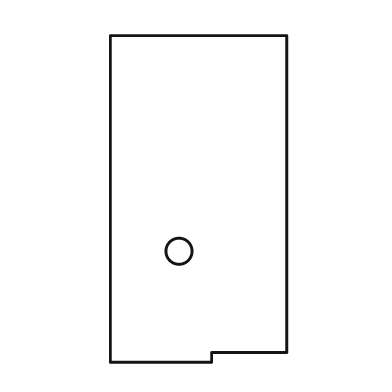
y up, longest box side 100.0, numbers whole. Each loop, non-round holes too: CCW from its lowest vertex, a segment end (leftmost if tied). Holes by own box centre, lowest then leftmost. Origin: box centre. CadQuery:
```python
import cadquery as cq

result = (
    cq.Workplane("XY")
    .moveTo(-27.0, -50.0)
    .lineTo(4.0, -50.0)
    .lineTo(4.0, -47.0)
    .lineTo(27.0, -47.0)
    .lineTo(27.0, 50.0)
    .lineTo(-27.0, 50.0)
    .close()
    .moveTo(-6.0, -16.0)
    .circle(4.0)
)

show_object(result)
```